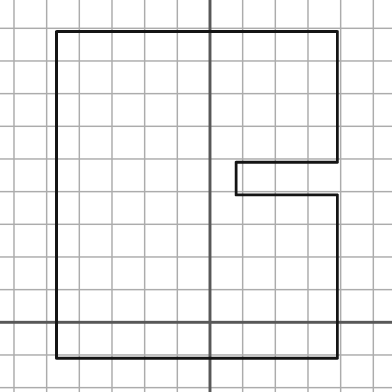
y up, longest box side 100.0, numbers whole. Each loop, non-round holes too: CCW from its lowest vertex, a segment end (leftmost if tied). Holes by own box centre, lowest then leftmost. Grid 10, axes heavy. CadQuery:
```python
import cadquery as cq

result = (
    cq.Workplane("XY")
    .moveTo(-47.0, -11.0)
    .lineTo(39.0, -11.0)
    .lineTo(39.0, 39.0)
    .lineTo(8.0, 39.0)
    .lineTo(8.0, 49.0)
    .lineTo(39.0, 49.0)
    .lineTo(39.0, 89.0)
    .lineTo(-47.0, 89.0)
    .close()
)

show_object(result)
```